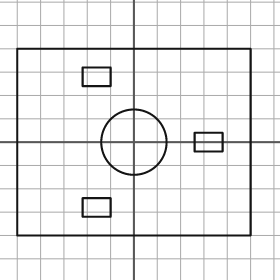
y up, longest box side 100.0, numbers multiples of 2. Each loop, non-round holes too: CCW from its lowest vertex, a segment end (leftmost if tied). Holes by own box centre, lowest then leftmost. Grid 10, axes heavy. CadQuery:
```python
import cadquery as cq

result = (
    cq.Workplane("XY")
    .moveTo(-50.0, -40.0)
    .lineTo(50.0, -40.0)
    .lineTo(50.0, 40.0)
    .lineTo(-50.0, 40.0)
    .close()
    .moveTo(-22.0, -32.0)
    .lineTo(-10.0, -32.0)
    .lineTo(-10.0, -24.0)
    .lineTo(-22.0, -24.0)
    .close()
    .moveTo(0.0, 0.0)
    .circle(14.0)
    .moveTo(26.0, -4.0)
    .lineTo(38.0, -4.0)
    .lineTo(38.0, 4.0)
    .lineTo(26.0, 4.0)
    .close()
    .moveTo(-22.0, 24.0)
    .lineTo(-10.0, 24.0)
    .lineTo(-10.0, 32.0)
    .lineTo(-22.0, 32.0)
    .close()
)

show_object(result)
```